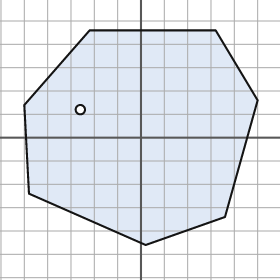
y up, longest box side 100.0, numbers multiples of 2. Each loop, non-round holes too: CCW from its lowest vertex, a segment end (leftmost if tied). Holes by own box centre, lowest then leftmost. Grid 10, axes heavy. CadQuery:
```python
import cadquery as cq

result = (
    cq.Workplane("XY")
    .moveTo(2.0, -46.0)
    .lineTo(36.0, -34.0)
    .lineTo(50.0, 16.0)
    .lineTo(32.0, 46.0)
    .lineTo(-22.0, 46.0)
    .lineTo(-50.0, 14.0)
    .lineTo(-48.0, -24.0)
    .close()
    .moveTo(-26.0, 12.0)
    .circle(2.0)
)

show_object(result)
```